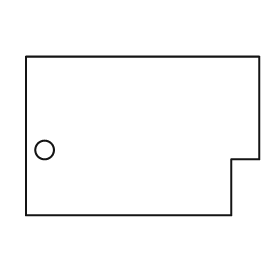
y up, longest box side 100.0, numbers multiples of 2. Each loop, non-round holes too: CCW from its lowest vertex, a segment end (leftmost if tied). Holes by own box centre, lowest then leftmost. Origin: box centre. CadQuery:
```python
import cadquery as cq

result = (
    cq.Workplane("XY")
    .moveTo(-50.0, -34.0)
    .lineTo(38.0, -34.0)
    .lineTo(38.0, -10.0)
    .lineTo(50.0, -10.0)
    .lineTo(50.0, 34.0)
    .lineTo(-50.0, 34.0)
    .close()
    .moveTo(-42.0, -6.0)
    .circle(4.0)
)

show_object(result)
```